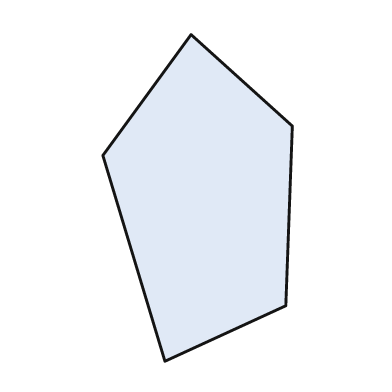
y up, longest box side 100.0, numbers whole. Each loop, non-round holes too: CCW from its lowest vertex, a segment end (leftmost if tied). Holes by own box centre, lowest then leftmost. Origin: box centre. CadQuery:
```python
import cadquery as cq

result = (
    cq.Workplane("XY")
    .moveTo(-10.0, -50.0)
    .lineTo(27.0, -33.0)
    .lineTo(29.0, 22.0)
    .lineTo(-2.0, 50.0)
    .lineTo(-29.0, 13.0)
    .close()
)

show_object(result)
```